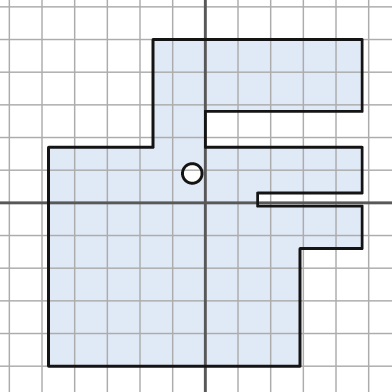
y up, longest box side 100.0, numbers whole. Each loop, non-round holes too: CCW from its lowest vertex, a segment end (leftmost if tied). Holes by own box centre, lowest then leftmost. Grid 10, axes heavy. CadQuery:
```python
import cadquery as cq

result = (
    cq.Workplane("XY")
    .moveTo(-48.0, -50.0)
    .lineTo(29.0, -50.0)
    .lineTo(29.0, -14.0)
    .lineTo(48.0, -14.0)
    .lineTo(48.0, -1.0)
    .lineTo(16.0, -1.0)
    .lineTo(16.0, 3.0)
    .lineTo(48.0, 3.0)
    .lineTo(48.0, 17.0)
    .lineTo(0.0, 17.0)
    .lineTo(0.0, 28.0)
    .lineTo(48.0, 28.0)
    .lineTo(48.0, 50.0)
    .lineTo(-16.0, 50.0)
    .lineTo(-16.0, 17.0)
    .lineTo(-48.0, 17.0)
    .close()
    .moveTo(-4.0, 9.0)
    .circle(3.0)
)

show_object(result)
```